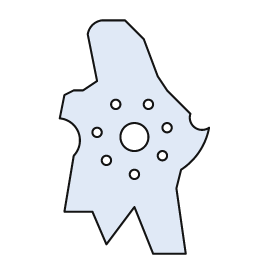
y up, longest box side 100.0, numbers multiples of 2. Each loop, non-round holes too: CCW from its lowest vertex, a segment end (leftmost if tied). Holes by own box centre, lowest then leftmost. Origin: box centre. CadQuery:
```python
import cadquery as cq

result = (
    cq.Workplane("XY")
    .moveTo(8.0, -50.0)
    .lineTo(22.0, -50.0)
    .lineTo(18.0, -22.0)
    .lineTo(20.0, -14.0)
    .threePointArc((28.0, -6.0), (32.0, 4.0))
    .threePointArc((26.0, 4.0), (24.0, 10.0))
    .lineTo(14.0, 20.0)
    .lineTo(10.0, 26.0)
    .lineTo(4.0, 42.0)
    .lineTo(-4.0, 50.0)
    .lineTo(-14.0, 50.0)
    .threePointArc((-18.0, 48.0), (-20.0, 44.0))
    .lineTo(-16.0, 24.0)
    .lineTo(-22.0, 20.0)
    .lineTo(-26.0, 20.0)
    .lineTo(-30.0, 18.0)
    .lineTo(-32.0, 8.0)
    .threePointArc((-24.0, 2.0), (-26.0, -8.0))
    .lineTo(-30.0, -32.0)
    .lineTo(-18.0, -32.0)
    .lineTo(-12.0, -46.0)
    .lineTo(0.0, -30.0)
    .close()
    .moveTo(0.0, -16.0)
    .circle(2.0)
    .moveTo(-12.0, -10.0)
    .circle(2.0)
    .moveTo(12.0, -8.0)
    .circle(2.0)
    .moveTo(0.0, 0.0)
    .circle(6.0)
    .moveTo(-16.0, 2.0)
    .circle(2.0)
    .moveTo(14.0, 4.0)
    .circle(2.0)
    .moveTo(-8.0, 14.0)
    .circle(2.0)
    .moveTo(6.0, 14.0)
    .circle(2.0)
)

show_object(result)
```